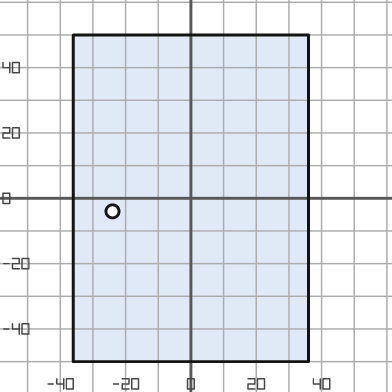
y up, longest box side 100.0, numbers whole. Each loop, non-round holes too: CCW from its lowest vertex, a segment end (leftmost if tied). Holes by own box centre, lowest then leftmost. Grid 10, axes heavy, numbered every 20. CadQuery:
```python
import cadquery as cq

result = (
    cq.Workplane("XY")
    .moveTo(-36.0, -50.0)
    .lineTo(36.0, -50.0)
    .lineTo(36.0, 50.0)
    .lineTo(-36.0, 50.0)
    .close()
    .moveTo(-24.0, -4.0)
    .circle(2.0)
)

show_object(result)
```